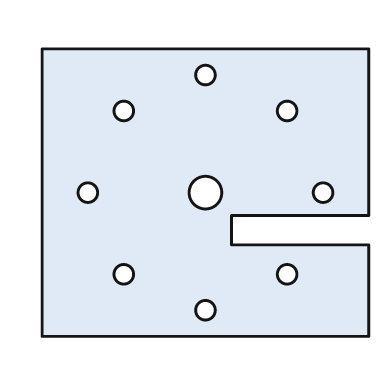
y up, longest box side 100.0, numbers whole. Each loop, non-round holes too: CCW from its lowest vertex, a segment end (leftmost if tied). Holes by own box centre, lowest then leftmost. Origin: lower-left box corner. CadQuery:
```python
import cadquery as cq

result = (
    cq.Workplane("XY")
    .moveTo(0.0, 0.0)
    .lineTo(100.0, 0.0)
    .lineTo(100.0, 28.0)
    .lineTo(58.0, 28.0)
    .lineTo(58.0, 37.0)
    .lineTo(100.0, 37.0)
    .lineTo(100.0, 88.0)
    .lineTo(0.0, 88.0)
    .close()
    .moveTo(50.0, 8.0)
    .circle(3.0)
    .moveTo(25.0, 19.0)
    .circle(3.0)
    .moveTo(75.0, 19.0)
    .circle(3.0)
    .moveTo(14.0, 44.0)
    .circle(3.0)
    .moveTo(50.0, 44.0)
    .circle(5.0)
    .moveTo(86.0, 44.0)
    .circle(3.0)
    .moveTo(25.0, 69.0)
    .circle(3.0)
    .moveTo(75.0, 69.0)
    .circle(3.0)
    .moveTo(50.0, 80.0)
    .circle(3.0)
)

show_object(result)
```